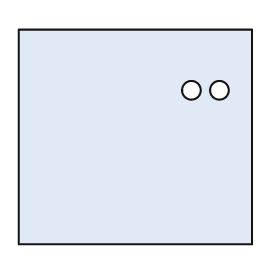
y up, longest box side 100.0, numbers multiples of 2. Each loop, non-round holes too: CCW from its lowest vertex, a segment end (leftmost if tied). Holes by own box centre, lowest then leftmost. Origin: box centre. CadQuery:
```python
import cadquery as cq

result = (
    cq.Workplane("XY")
    .moveTo(-50.0, -46.0)
    .lineTo(50.0, -46.0)
    .lineTo(50.0, 46.0)
    .lineTo(-50.0, 46.0)
    .close()
    .moveTo(24.0, 20.0)
    .circle(4.0)
    .moveTo(36.0, 20.0)
    .circle(4.0)
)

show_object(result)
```